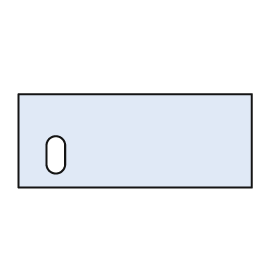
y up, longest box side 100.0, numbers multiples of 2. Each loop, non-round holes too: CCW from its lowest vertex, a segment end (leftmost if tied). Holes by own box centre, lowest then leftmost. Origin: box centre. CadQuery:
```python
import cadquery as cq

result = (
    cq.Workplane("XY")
    .moveTo(-50.0, -20.0)
    .lineTo(50.0, -20.0)
    .lineTo(50.0, 20.0)
    .lineTo(-50.0, 20.0)
    .close()
    .moveTo(-38.0, -10.0)
    .threePointArc((-34.0, -14.0), (-30.0, -10.0))
    .lineTo(-30.0, -2.0)
    .threePointArc((-34.0, 2.0), (-38.0, -2.0))
    .close()
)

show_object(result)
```